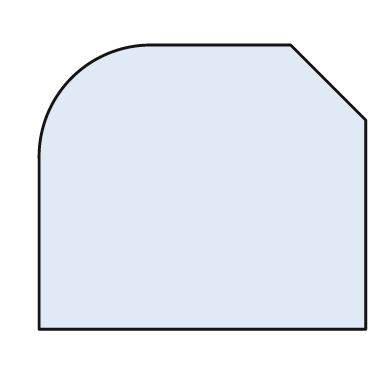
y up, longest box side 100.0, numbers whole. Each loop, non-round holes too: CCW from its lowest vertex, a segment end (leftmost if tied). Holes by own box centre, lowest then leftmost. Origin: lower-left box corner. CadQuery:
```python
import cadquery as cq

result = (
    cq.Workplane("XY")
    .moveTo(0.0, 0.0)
    .lineTo(100.0, 0.0)
    .lineTo(100.0, 64.0)
    .lineTo(77.0, 87.0)
    .lineTo(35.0, 87.0)
    .threePointArc((10.0, 77.0), (0.0, 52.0))
    .close()
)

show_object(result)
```